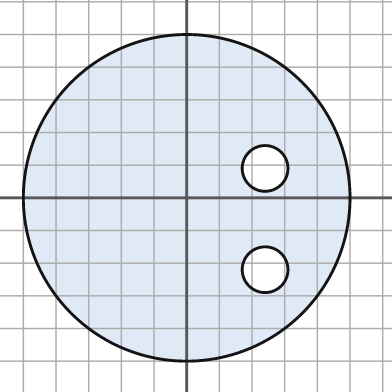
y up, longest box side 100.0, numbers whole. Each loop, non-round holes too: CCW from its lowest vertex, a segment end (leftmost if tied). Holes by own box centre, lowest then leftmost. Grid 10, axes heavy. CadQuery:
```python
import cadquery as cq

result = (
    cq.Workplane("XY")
    .moveTo(0.0, 0.0)
    .circle(50.0)
    .moveTo(24.0, -22.0)
    .circle(7.0)
    .moveTo(24.0, 9.0)
    .circle(7.0)
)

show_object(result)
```